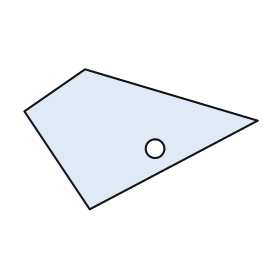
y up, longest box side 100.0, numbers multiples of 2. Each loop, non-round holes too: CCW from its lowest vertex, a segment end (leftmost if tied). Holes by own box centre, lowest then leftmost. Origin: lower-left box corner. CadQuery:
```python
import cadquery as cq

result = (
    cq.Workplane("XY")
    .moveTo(28.0, 0.0)
    .lineTo(100.0, 38.0)
    .lineTo(26.0, 60.0)
    .lineTo(0.0, 42.0)
    .close()
    .moveTo(56.0, 26.0)
    .circle(4.0)
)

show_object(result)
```